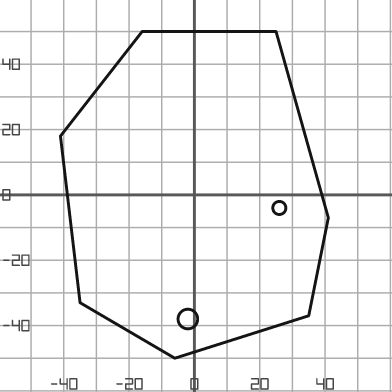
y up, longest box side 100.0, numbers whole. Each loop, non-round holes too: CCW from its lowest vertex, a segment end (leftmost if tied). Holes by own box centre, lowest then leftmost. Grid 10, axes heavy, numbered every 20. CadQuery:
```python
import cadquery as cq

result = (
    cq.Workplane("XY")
    .moveTo(-6.0, -50.0)
    .lineTo(35.0, -37.0)
    .lineTo(41.0, -7.0)
    .lineTo(25.0, 50.0)
    .lineTo(-16.0, 50.0)
    .lineTo(-41.0, 18.0)
    .lineTo(-35.0, -33.0)
    .close()
    .moveTo(-2.0, -38.0)
    .circle(3.0)
    .moveTo(26.0, -4.0)
    .circle(2.0)
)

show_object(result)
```